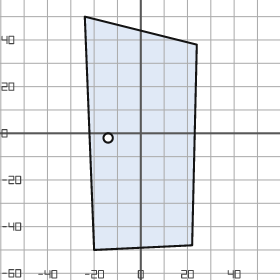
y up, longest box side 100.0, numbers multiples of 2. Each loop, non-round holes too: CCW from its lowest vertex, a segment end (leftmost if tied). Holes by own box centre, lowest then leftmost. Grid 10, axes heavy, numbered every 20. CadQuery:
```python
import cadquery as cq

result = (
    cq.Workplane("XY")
    .moveTo(-20.0, -50.0)
    .lineTo(22.0, -48.0)
    .lineTo(24.0, 38.0)
    .lineTo(-24.0, 50.0)
    .close()
    .moveTo(-14.0, -2.0)
    .circle(2.0)
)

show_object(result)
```